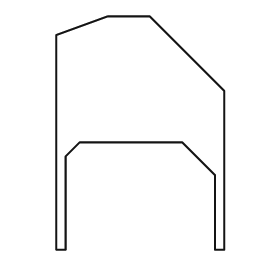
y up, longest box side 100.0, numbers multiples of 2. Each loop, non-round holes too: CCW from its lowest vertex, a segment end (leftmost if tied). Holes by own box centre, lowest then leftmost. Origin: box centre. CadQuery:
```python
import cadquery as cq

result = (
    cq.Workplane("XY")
    .moveTo(-36.0, -50.0)
    .lineTo(-32.0, -50.0)
    .lineTo(-32.0, -10.0)
    .lineTo(-26.0, -4.0)
    .lineTo(18.0, -4.0)
    .lineTo(32.0, -18.0)
    .lineTo(32.0, -50.0)
    .lineTo(36.0, -50.0)
    .lineTo(36.0, 18.0)
    .lineTo(4.0, 50.0)
    .lineTo(-14.0, 50.0)
    .lineTo(-36.0, 42.0)
    .close()
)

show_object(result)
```